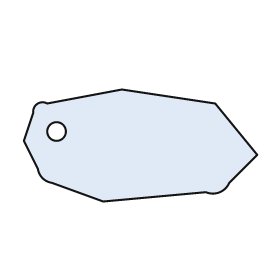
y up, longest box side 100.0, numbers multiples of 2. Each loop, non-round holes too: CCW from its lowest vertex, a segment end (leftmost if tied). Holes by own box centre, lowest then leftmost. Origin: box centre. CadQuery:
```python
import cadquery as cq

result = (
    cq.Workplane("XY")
    .moveTo(-16.0, -24.0)
    .lineTo(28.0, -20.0)
    .threePointArc((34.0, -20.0), (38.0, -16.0))
    .lineTo(50.0, -4.0)
    .lineTo(32.0, 18.0)
    .lineTo(-8.0, 24.0)
    .lineTo(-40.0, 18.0)
    .threePointArc((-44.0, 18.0), (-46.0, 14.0))
    .lineTo(-50.0, 2.0)
    .lineTo(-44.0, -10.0)
    .threePointArc((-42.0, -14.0), (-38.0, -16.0))
    .close()
    .moveTo(-36.0, 6.0)
    .circle(4.0)
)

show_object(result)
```